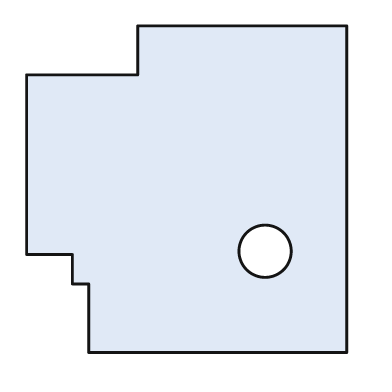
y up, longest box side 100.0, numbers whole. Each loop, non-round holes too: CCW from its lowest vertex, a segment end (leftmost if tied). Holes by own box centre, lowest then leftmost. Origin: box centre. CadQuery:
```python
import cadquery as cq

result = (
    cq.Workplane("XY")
    .moveTo(-30.0, -50.0)
    .lineTo(49.0, -50.0)
    .lineTo(49.0, 50.0)
    .lineTo(-15.0, 50.0)
    .lineTo(-15.0, 35.0)
    .lineTo(-49.0, 35.0)
    .lineTo(-49.0, -20.0)
    .lineTo(-35.0, -20.0)
    .lineTo(-35.0, -29.0)
    .lineTo(-30.0, -29.0)
    .close()
    .moveTo(24.0, -19.0)
    .circle(8.0)
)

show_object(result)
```